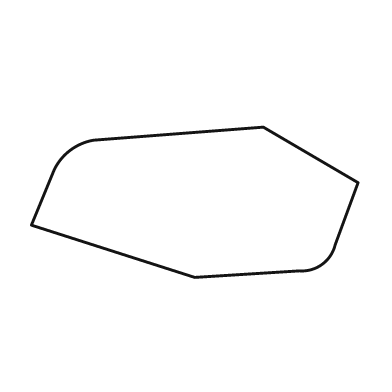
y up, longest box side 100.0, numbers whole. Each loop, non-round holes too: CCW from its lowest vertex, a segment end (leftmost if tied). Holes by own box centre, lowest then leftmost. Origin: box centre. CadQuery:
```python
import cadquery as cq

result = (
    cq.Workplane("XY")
    .moveTo(0.0, -23.0)
    .lineTo(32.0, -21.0)
    .threePointArc((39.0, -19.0), (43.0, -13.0))
    .lineTo(50.0, 6.0)
    .lineTo(21.0, 23.0)
    .lineTo(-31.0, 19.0)
    .threePointArc((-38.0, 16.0), (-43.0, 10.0))
    .lineTo(-50.0, -7.0)
    .close()
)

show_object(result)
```